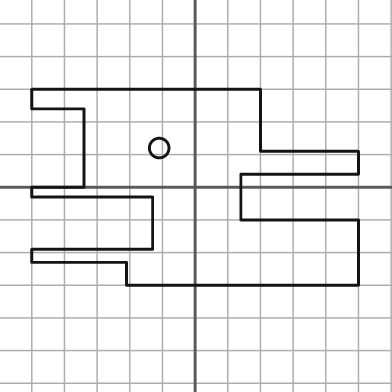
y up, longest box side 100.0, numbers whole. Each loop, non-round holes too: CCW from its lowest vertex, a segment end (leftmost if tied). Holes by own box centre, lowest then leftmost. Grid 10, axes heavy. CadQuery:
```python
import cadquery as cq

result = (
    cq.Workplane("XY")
    .moveTo(-21.0, -30.0)
    .lineTo(50.0, -30.0)
    .lineTo(50.0, -10.0)
    .lineTo(14.0, -10.0)
    .lineTo(14.0, 4.0)
    .lineTo(50.0, 4.0)
    .lineTo(50.0, 11.0)
    .lineTo(20.0, 11.0)
    .lineTo(20.0, 30.0)
    .lineTo(-50.0, 30.0)
    .lineTo(-50.0, 24.0)
    .lineTo(-34.0, 24.0)
    .lineTo(-34.0, 0.0)
    .lineTo(-50.0, 0.0)
    .lineTo(-50.0, -3.0)
    .lineTo(-13.0, -3.0)
    .lineTo(-13.0, -19.0)
    .lineTo(-50.0, -19.0)
    .lineTo(-50.0, -23.0)
    .lineTo(-21.0, -23.0)
    .close()
    .moveTo(-11.0, 12.0)
    .circle(3.0)
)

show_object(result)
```